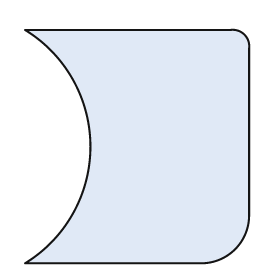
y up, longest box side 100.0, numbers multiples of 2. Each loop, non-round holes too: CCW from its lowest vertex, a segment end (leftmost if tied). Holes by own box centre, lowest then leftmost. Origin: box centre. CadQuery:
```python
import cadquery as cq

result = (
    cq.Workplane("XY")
    .moveTo(-48.0, -50.0)
    .lineTo(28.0, -50.0)
    .threePointArc((42.0, -44.0), (48.0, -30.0))
    .lineTo(48.0, 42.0)
    .threePointArc((46.0, 48.0), (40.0, 50.0))
    .lineTo(-48.0, 50.0)
    .threePointArc((-20.0, 0.0), (-48.0, -50.0))
    .close()
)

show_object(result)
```